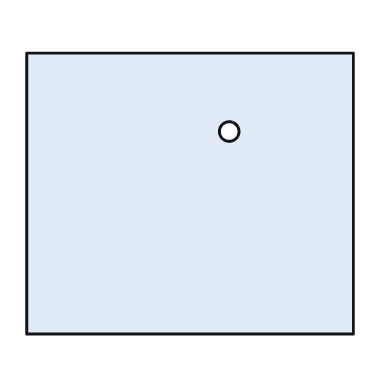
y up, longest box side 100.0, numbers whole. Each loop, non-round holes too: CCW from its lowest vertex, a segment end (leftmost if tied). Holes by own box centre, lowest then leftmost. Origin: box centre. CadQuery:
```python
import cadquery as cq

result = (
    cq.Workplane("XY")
    .moveTo(-50.0, -43.0)
    .lineTo(50.0, -43.0)
    .lineTo(50.0, 43.0)
    .lineTo(-50.0, 43.0)
    .close()
    .moveTo(12.0, 19.0)
    .circle(3.0)
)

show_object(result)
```